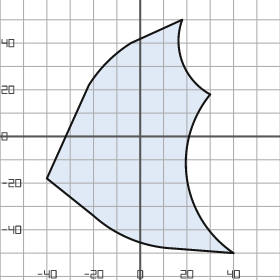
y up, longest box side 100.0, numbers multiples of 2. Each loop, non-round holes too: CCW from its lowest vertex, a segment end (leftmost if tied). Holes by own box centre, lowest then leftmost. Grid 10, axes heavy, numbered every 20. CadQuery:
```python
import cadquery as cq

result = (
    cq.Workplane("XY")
    .moveTo(40.0, -50.0)
    .threePointArc((20.0, -18.0), (30.0, 18.0))
    .threePointArc((18.0, 32.0), (18.0, 50.0))
    .lineTo(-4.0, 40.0)
    .threePointArc((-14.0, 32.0), (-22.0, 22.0))
    .lineTo(-40.0, -18.0)
    .lineTo(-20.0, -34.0)
    .threePointArc((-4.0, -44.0), (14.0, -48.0))
    .close()
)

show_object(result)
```